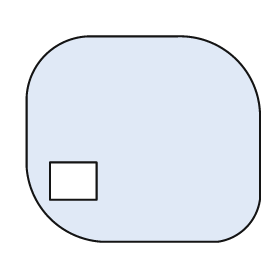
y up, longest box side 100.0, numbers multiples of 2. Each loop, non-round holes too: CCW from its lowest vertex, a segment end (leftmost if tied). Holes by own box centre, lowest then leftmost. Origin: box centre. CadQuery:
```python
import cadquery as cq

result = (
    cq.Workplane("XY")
    .moveTo(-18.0, -44.0)
    .lineTo(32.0, -44.0)
    .threePointArc((44.0, -38.0), (50.0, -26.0))
    .lineTo(50.0, 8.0)
    .threePointArc((40.0, 34.0), (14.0, 44.0))
    .lineTo(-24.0, 44.0)
    .threePointArc((-42.0, 36.0), (-50.0, 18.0))
    .lineTo(-50.0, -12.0)
    .threePointArc((-40.0, -34.0), (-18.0, -44.0))
    .close()
    .moveTo(-40.0, -26.0)
    .lineTo(-20.0, -26.0)
    .lineTo(-20.0, -10.0)
    .lineTo(-40.0, -10.0)
    .close()
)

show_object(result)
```